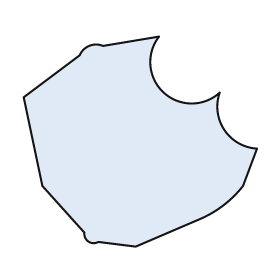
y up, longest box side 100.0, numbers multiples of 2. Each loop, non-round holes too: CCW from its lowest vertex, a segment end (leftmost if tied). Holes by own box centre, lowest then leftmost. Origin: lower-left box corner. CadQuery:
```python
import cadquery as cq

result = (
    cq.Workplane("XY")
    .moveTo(48.0, 0.0)
    .lineTo(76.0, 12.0)
    .threePointArc((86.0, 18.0), (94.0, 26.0))
    .lineTo(100.0, 42.0)
    .threePointArc((86.0, 50.0), (84.0, 66.0))
    .threePointArc((60.0, 66.0), (58.0, 90.0))
    .lineTo(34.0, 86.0)
    .threePointArc((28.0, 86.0), (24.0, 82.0))
    .lineTo(0.0, 64.0)
    .lineTo(8.0, 26.0)
    .lineTo(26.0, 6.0)
    .threePointArc((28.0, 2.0), (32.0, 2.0))
    .close()
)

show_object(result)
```